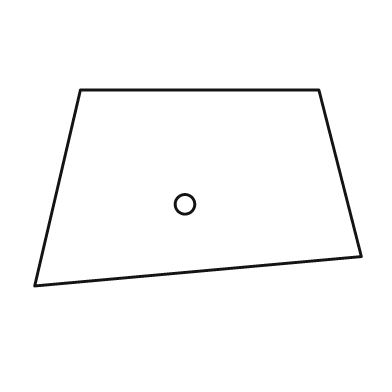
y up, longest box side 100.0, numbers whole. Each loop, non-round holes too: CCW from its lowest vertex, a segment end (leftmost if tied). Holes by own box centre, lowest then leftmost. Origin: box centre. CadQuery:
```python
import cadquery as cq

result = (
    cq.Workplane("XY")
    .moveTo(-50.0, -30.0)
    .lineTo(50.0, -21.0)
    .lineTo(37.0, 30.0)
    .lineTo(-36.0, 30.0)
    .close()
    .moveTo(-4.0, -5.0)
    .circle(3.0)
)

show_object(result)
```